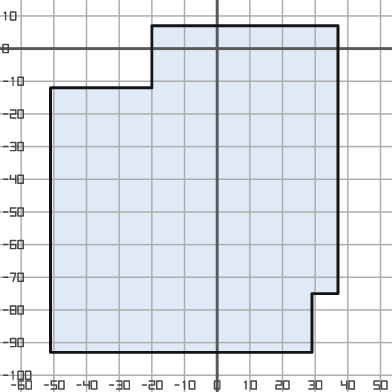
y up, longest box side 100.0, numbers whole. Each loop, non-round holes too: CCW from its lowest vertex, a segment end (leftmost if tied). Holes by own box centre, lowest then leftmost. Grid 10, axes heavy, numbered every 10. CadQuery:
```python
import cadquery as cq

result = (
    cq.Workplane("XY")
    .moveTo(-51.0, -93.0)
    .lineTo(29.0, -93.0)
    .lineTo(29.0, -75.0)
    .lineTo(37.0, -75.0)
    .lineTo(37.0, 7.0)
    .lineTo(-20.0, 7.0)
    .lineTo(-20.0, -12.0)
    .lineTo(-51.0, -12.0)
    .close()
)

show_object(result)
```